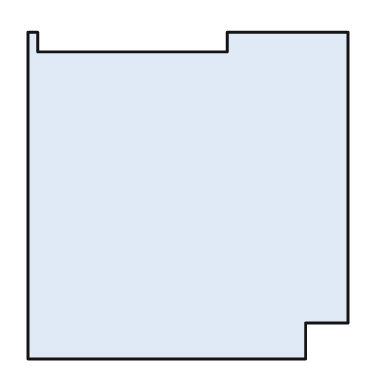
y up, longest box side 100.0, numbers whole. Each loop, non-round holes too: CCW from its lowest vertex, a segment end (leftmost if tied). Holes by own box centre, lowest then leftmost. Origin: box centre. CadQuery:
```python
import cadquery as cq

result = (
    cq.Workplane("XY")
    .moveTo(-49.0, -50.0)
    .lineTo(36.0, -50.0)
    .lineTo(36.0, -39.0)
    .lineTo(49.0, -39.0)
    .lineTo(49.0, 50.0)
    .lineTo(12.0, 50.0)
    .lineTo(12.0, 44.0)
    .lineTo(-46.0, 44.0)
    .lineTo(-46.0, 50.0)
    .lineTo(-49.0, 50.0)
    .close()
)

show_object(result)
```